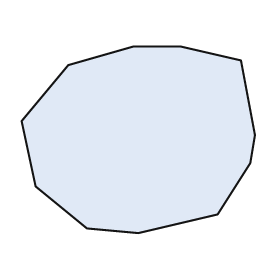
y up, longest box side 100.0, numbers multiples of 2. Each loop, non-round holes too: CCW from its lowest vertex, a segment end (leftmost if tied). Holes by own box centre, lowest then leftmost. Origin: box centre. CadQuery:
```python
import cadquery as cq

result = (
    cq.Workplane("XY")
    .moveTo(0.0, -40.0)
    .lineTo(34.0, -32.0)
    .lineTo(48.0, -10.0)
    .lineTo(50.0, 2.0)
    .lineTo(44.0, 34.0)
    .lineTo(18.0, 40.0)
    .lineTo(-2.0, 40.0)
    .lineTo(-30.0, 32.0)
    .lineTo(-50.0, 8.0)
    .lineTo(-44.0, -20.0)
    .lineTo(-22.0, -38.0)
    .close()
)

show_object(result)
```